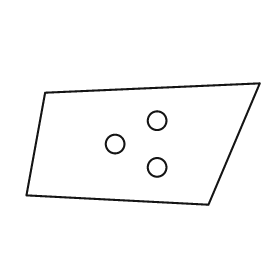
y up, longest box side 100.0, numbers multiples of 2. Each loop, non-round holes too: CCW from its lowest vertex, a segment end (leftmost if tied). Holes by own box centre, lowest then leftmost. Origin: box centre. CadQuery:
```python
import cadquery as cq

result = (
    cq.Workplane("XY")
    .moveTo(28.0, -26.0)
    .lineTo(50.0, 26.0)
    .lineTo(-42.0, 22.0)
    .lineTo(-50.0, -22.0)
    .close()
    .moveTo(6.0, -10.0)
    .circle(4.0)
    .moveTo(-12.0, 0.0)
    .circle(4.0)
    .moveTo(6.0, 10.0)
    .circle(4.0)
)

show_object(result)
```